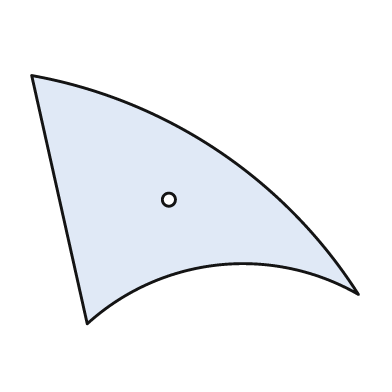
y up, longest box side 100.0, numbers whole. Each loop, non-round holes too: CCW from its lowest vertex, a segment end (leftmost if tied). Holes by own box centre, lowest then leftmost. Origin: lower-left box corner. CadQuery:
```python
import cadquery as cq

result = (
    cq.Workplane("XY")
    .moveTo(17.0, 0.0)
    .threePointArc((57.0, 18.0), (100.0, 9.0))
    .threePointArc((57.0, 53.0), (0.0, 76.0))
    .close()
    .moveTo(42.0, 38.0)
    .circle(2.0)
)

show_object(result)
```